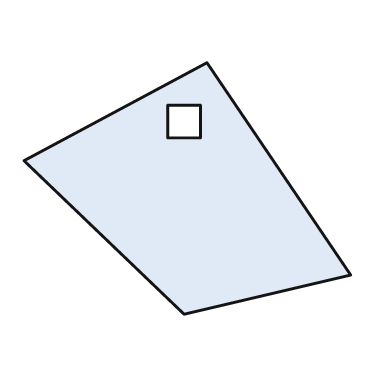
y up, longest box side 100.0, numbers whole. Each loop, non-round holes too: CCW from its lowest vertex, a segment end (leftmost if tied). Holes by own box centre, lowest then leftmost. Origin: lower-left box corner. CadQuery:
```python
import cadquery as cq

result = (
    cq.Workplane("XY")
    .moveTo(49.0, 0.0)
    .lineTo(100.0, 12.0)
    .lineTo(56.0, 77.0)
    .lineTo(0.0, 47.0)
    .close()
    .moveTo(44.0, 54.0)
    .lineTo(54.0, 54.0)
    .lineTo(54.0, 64.0)
    .lineTo(44.0, 64.0)
    .close()
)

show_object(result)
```